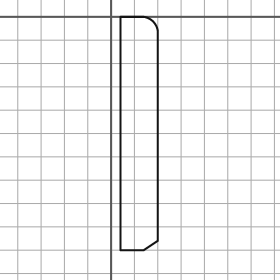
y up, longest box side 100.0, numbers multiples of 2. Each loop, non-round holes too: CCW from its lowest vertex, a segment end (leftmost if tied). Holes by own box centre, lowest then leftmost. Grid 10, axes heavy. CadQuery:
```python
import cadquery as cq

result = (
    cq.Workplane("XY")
    .moveTo(4.0, -100.0)
    .lineTo(14.0, -100.0)
    .lineTo(20.0, -96.0)
    .lineTo(20.0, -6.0)
    .threePointArc((18.0, -2.0), (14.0, 0.0))
    .lineTo(4.0, 0.0)
    .close()
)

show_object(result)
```